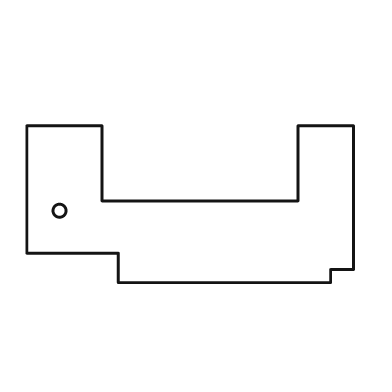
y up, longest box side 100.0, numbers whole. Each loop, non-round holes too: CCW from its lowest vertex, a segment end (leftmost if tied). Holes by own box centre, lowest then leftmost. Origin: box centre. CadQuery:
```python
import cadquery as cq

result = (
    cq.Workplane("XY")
    .moveTo(-22.0, -24.0)
    .lineTo(43.0, -24.0)
    .lineTo(43.0, -20.0)
    .lineTo(50.0, -20.0)
    .lineTo(50.0, 24.0)
    .lineTo(33.0, 24.0)
    .lineTo(33.0, 1.0)
    .lineTo(-27.0, 1.0)
    .lineTo(-27.0, 24.0)
    .lineTo(-50.0, 24.0)
    .lineTo(-50.0, -15.0)
    .lineTo(-22.0, -15.0)
    .close()
    .moveTo(-40.0, -2.0)
    .circle(2.0)
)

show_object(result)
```